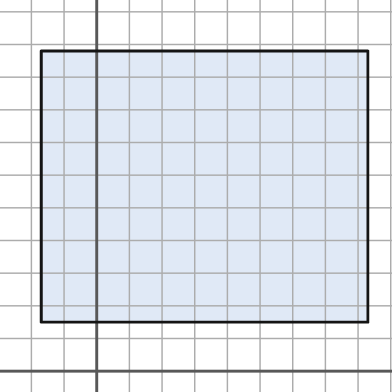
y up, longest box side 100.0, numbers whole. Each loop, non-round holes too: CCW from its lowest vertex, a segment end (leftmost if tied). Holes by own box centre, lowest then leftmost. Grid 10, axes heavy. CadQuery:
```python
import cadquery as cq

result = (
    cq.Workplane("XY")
    .moveTo(-17.0, 15.0)
    .lineTo(83.0, 15.0)
    .lineTo(83.0, 98.0)
    .lineTo(-17.0, 98.0)
    .close()
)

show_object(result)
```